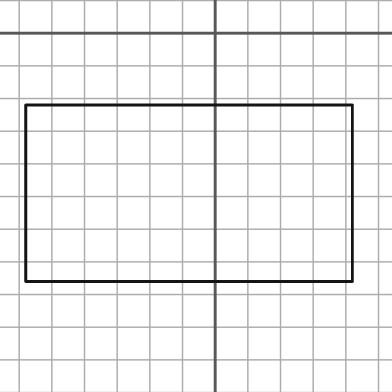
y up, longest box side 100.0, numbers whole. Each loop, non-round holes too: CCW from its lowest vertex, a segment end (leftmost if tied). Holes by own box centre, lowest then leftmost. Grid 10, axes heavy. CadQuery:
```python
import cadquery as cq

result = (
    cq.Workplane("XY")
    .moveTo(-58.0, -76.0)
    .lineTo(42.0, -76.0)
    .lineTo(42.0, -22.0)
    .lineTo(-58.0, -22.0)
    .close()
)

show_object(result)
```